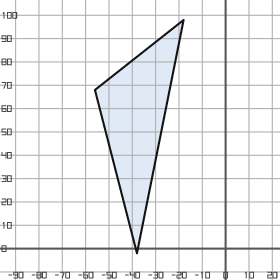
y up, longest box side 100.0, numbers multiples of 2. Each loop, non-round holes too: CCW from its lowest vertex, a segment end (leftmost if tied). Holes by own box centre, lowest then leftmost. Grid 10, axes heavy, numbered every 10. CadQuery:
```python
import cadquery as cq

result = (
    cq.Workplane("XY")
    .moveTo(-38.0, -2.0)
    .lineTo(-18.0, 98.0)
    .lineTo(-56.0, 68.0)
    .close()
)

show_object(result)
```